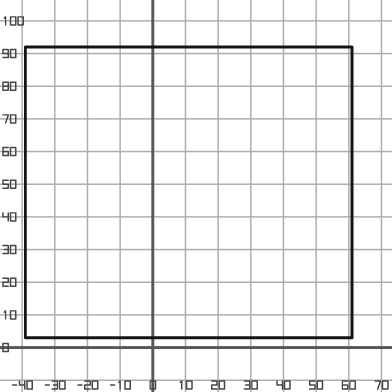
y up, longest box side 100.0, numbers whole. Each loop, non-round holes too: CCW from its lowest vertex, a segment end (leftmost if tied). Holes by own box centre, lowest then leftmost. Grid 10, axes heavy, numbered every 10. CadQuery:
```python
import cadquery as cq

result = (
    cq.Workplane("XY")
    .moveTo(-39.0, 3.0)
    .lineTo(61.0, 3.0)
    .lineTo(61.0, 92.0)
    .lineTo(-39.0, 92.0)
    .close()
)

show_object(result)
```